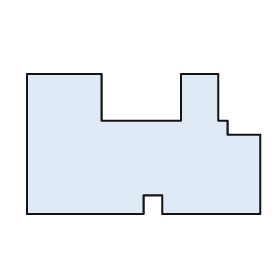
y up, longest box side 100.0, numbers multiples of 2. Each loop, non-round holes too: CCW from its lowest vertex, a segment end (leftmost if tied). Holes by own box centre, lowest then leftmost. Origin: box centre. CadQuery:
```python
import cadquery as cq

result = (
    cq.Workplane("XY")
    .moveTo(-50.0, -30.0)
    .lineTo(0.0, -30.0)
    .lineTo(0.0, -22.0)
    .lineTo(8.0, -22.0)
    .lineTo(8.0, -30.0)
    .lineTo(50.0, -30.0)
    .lineTo(50.0, 4.0)
    .lineTo(36.0, 4.0)
    .lineTo(36.0, 10.0)
    .lineTo(32.0, 10.0)
    .lineTo(32.0, 30.0)
    .lineTo(16.0, 30.0)
    .lineTo(16.0, 10.0)
    .lineTo(-18.0, 10.0)
    .lineTo(-18.0, 30.0)
    .lineTo(-50.0, 30.0)
    .close()
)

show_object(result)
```